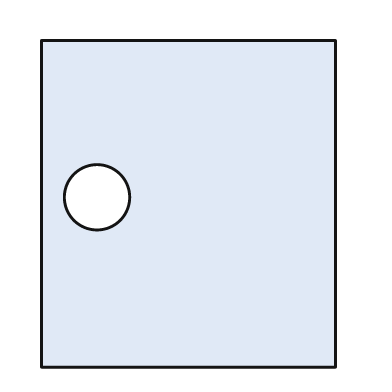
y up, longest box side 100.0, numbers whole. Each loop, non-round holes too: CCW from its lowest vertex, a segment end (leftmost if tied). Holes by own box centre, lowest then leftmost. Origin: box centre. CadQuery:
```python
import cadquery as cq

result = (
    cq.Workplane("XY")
    .moveTo(-45.0, -50.0)
    .lineTo(45.0, -50.0)
    .lineTo(45.0, 50.0)
    .lineTo(-45.0, 50.0)
    .close()
    .moveTo(-28.0, 2.0)
    .circle(10.0)
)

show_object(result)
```